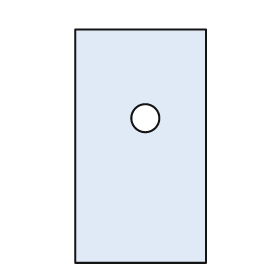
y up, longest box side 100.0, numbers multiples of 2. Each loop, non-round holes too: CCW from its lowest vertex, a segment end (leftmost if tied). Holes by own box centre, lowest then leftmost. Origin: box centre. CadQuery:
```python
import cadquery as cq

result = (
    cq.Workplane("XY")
    .moveTo(-28.0, -50.0)
    .lineTo(28.0, -50.0)
    .lineTo(28.0, 50.0)
    .lineTo(-28.0, 50.0)
    .close()
    .moveTo(2.0, 12.0)
    .circle(6.0)
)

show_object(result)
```